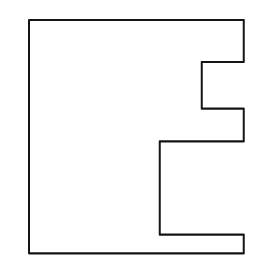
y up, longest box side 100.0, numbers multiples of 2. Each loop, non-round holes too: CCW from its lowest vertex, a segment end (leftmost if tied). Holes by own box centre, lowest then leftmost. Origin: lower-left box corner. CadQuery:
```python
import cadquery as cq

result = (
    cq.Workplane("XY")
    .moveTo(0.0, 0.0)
    .lineTo(92.0, 0.0)
    .lineTo(92.0, 8.0)
    .lineTo(56.0, 8.0)
    .lineTo(56.0, 48.0)
    .lineTo(92.0, 48.0)
    .lineTo(92.0, 62.0)
    .lineTo(74.0, 62.0)
    .lineTo(74.0, 82.0)
    .lineTo(92.0, 82.0)
    .lineTo(92.0, 100.0)
    .lineTo(0.0, 100.0)
    .close()
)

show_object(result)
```